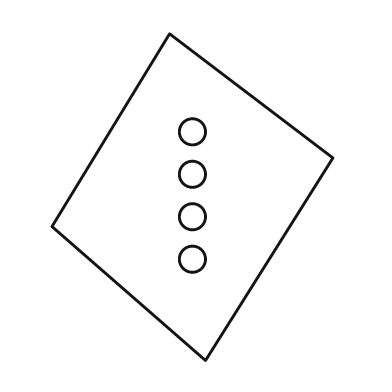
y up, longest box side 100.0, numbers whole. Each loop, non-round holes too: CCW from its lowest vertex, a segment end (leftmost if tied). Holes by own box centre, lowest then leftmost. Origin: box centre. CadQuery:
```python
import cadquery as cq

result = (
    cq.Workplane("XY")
    .moveTo(4.0, -50.0)
    .lineTo(43.0, 12.0)
    .lineTo(-7.0, 50.0)
    .lineTo(-43.0, -9.0)
    .close()
    .moveTo(0.0, -19.0)
    .circle(4.0)
    .moveTo(0.0, -6.0)
    .circle(4.0)
    .moveTo(0.0, 7.0)
    .circle(4.0)
    .moveTo(0.0, 20.0)
    .circle(4.0)
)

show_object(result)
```